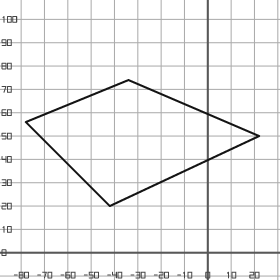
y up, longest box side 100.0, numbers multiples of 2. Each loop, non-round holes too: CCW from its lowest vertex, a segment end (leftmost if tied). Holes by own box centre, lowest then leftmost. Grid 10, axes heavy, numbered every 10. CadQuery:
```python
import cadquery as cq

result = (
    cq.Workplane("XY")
    .moveTo(-42.0, 20.0)
    .lineTo(22.0, 50.0)
    .lineTo(-34.0, 74.0)
    .lineTo(-78.0, 56.0)
    .close()
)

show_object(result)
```